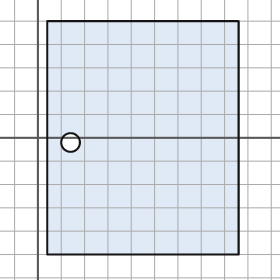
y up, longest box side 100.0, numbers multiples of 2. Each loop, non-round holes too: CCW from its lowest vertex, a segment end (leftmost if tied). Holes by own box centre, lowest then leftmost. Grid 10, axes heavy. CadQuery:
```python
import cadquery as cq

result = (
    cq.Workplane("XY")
    .moveTo(4.0, -50.0)
    .lineTo(86.0, -50.0)
    .lineTo(86.0, 50.0)
    .lineTo(4.0, 50.0)
    .close()
    .moveTo(14.0, -2.0)
    .circle(4.0)
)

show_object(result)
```